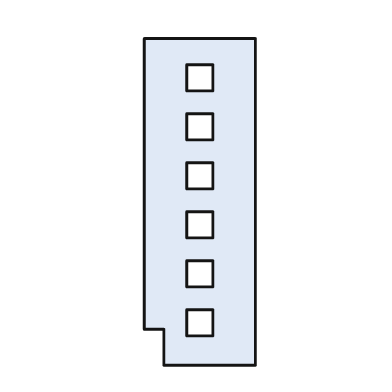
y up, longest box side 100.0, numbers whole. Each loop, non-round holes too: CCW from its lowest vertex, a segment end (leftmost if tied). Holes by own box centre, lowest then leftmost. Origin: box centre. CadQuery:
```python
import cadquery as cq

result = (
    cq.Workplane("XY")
    .moveTo(-11.0, -50.0)
    .lineTo(17.0, -50.0)
    .lineTo(17.0, 50.0)
    .lineTo(-17.0, 50.0)
    .lineTo(-17.0, -39.0)
    .lineTo(-11.0, -39.0)
    .close()
    .moveTo(-4.0, -41.0)
    .lineTo(4.0, -41.0)
    .lineTo(4.0, -33.0)
    .lineTo(-4.0, -33.0)
    .close()
    .moveTo(-4.0, -26.0)
    .lineTo(4.0, -26.0)
    .lineTo(4.0, -18.0)
    .lineTo(-4.0, -18.0)
    .close()
    .moveTo(-4.0, -11.0)
    .lineTo(4.0, -11.0)
    .lineTo(4.0, -3.0)
    .lineTo(-4.0, -3.0)
    .close()
    .moveTo(-4.0, 4.0)
    .lineTo(4.0, 4.0)
    .lineTo(4.0, 12.0)
    .lineTo(-4.0, 12.0)
    .close()
    .moveTo(-4.0, 19.0)
    .lineTo(4.0, 19.0)
    .lineTo(4.0, 27.0)
    .lineTo(-4.0, 27.0)
    .close()
    .moveTo(-4.0, 34.0)
    .lineTo(4.0, 34.0)
    .lineTo(4.0, 42.0)
    .lineTo(-4.0, 42.0)
    .close()
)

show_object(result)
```